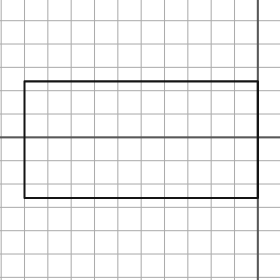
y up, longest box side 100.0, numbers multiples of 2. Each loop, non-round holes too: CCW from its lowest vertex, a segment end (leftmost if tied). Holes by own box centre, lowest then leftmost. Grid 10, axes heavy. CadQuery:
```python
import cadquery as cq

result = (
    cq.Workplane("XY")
    .moveTo(-100.0, -26.0)
    .lineTo(0.0, -26.0)
    .lineTo(0.0, 24.0)
    .lineTo(-100.0, 24.0)
    .close()
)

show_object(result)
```